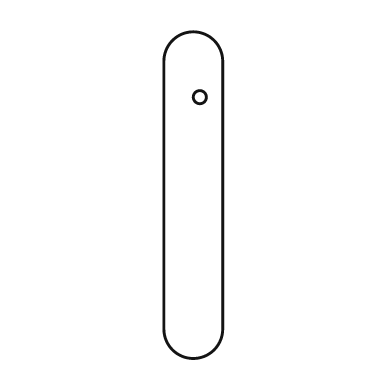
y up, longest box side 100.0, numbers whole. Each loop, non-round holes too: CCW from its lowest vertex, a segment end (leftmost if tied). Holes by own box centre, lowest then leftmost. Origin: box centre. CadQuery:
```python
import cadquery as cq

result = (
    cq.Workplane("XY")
    .moveTo(-9.0, -41.0)
    .threePointArc((0.0, -50.0), (9.0, -41.0))
    .lineTo(9.0, 41.0)
    .threePointArc((0.0, 50.0), (-9.0, 41.0))
    .close()
    .moveTo(2.0, 30.0)
    .circle(2.0)
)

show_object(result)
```